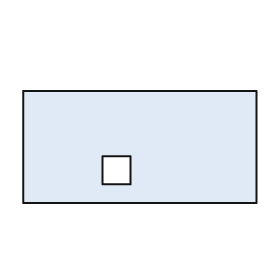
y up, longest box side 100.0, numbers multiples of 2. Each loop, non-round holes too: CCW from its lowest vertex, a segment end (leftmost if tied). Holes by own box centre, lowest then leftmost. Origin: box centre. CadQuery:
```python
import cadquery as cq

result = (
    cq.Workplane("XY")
    .moveTo(-50.0, -24.0)
    .lineTo(50.0, -24.0)
    .lineTo(50.0, 24.0)
    .lineTo(-50.0, 24.0)
    .close()
    .moveTo(-16.0, -16.0)
    .lineTo(-4.0, -16.0)
    .lineTo(-4.0, -4.0)
    .lineTo(-16.0, -4.0)
    .close()
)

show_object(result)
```